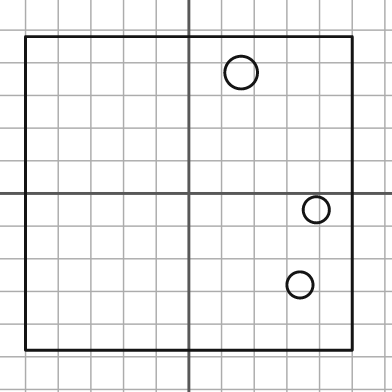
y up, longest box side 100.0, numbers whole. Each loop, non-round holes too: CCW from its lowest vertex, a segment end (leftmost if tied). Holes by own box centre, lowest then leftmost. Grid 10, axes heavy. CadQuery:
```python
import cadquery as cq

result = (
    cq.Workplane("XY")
    .moveTo(-50.0, -48.0)
    .lineTo(50.0, -48.0)
    .lineTo(50.0, 48.0)
    .lineTo(-50.0, 48.0)
    .close()
    .moveTo(34.0, -28.0)
    .circle(4.0)
    .moveTo(39.0, -5.0)
    .circle(4.0)
    .moveTo(16.0, 37.0)
    .circle(5.0)
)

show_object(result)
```